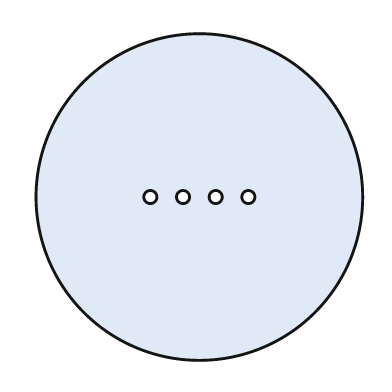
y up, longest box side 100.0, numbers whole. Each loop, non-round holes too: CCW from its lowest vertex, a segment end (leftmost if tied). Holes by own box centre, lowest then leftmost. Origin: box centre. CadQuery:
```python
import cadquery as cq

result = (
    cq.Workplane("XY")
    .moveTo(0.0, 0.0)
    .circle(50.0)
    .moveTo(-15.0, 0.0)
    .circle(2.0)
    .moveTo(-5.0, 0.0)
    .circle(2.0)
    .moveTo(5.0, 0.0)
    .circle(2.0)
    .moveTo(15.0, 0.0)
    .circle(2.0)
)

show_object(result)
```